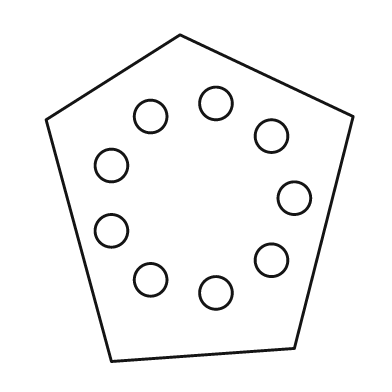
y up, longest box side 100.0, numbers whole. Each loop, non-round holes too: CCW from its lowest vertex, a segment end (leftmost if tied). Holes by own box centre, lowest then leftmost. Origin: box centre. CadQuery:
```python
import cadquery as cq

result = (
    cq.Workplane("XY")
    .moveTo(-27.0, -50.0)
    .lineTo(29.0, -46.0)
    .lineTo(47.0, 25.0)
    .lineTo(-6.0, 50.0)
    .lineTo(-47.0, 24.0)
    .close()
    .moveTo(5.0, -29.0)
    .circle(5.0)
    .moveTo(-15.0, -25.0)
    .circle(5.0)
    .moveTo(22.0, -19.0)
    .circle(5.0)
    .moveTo(-27.0, -10.0)
    .circle(5.0)
    .moveTo(29.0, 0.0)
    .circle(5.0)
    .moveTo(-27.0, 10.0)
    .circle(5.0)
    .moveTo(22.0, 19.0)
    .circle(5.0)
    .moveTo(-15.0, 25.0)
    .circle(5.0)
    .moveTo(5.0, 29.0)
    .circle(5.0)
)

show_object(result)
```